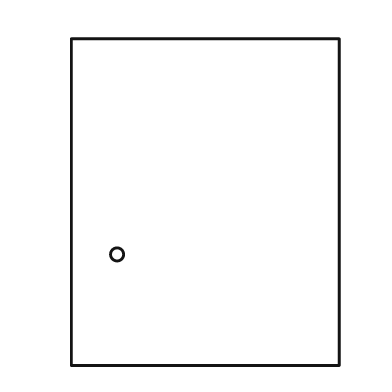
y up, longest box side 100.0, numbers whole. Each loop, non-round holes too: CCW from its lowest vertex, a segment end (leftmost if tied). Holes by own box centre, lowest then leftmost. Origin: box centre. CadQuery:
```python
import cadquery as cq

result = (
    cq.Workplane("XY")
    .moveTo(-41.0, -50.0)
    .lineTo(41.0, -50.0)
    .lineTo(41.0, 50.0)
    .lineTo(-41.0, 50.0)
    .close()
    .moveTo(-27.0, -16.0)
    .circle(2.0)
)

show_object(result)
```